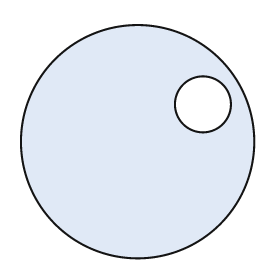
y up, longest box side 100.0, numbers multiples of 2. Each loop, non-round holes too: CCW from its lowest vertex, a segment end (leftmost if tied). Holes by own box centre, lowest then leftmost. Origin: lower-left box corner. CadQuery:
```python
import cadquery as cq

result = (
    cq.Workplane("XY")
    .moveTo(50.0, 50.0)
    .circle(50.0)
    .moveTo(78.0, 66.0)
    .circle(12.0)
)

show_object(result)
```